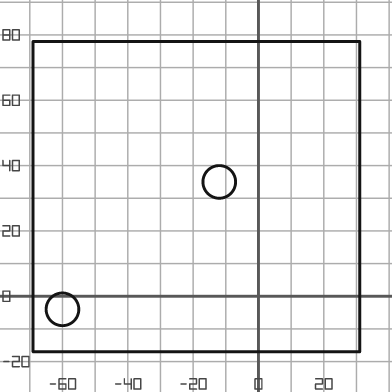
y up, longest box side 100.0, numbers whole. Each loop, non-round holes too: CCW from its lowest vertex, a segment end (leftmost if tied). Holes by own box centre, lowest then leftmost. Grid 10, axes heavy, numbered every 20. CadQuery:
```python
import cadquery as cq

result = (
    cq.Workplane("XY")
    .moveTo(-69.0, -17.0)
    .lineTo(31.0, -17.0)
    .lineTo(31.0, 78.0)
    .lineTo(-69.0, 78.0)
    .close()
    .moveTo(-60.0, -4.0)
    .circle(5.0)
    .moveTo(-12.0, 35.0)
    .circle(5.0)
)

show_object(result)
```